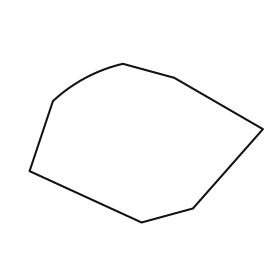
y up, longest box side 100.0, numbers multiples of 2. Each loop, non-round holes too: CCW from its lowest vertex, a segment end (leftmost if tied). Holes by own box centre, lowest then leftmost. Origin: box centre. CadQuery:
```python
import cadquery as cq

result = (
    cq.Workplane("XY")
    .moveTo(-2.0, -34.0)
    .lineTo(20.0, -28.0)
    .lineTo(50.0, 6.0)
    .lineTo(12.0, 28.0)
    .lineTo(-10.0, 34.0)
    .threePointArc((-26.0, 28.0), (-40.0, 18.0))
    .lineTo(-50.0, -12.0)
    .close()
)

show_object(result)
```